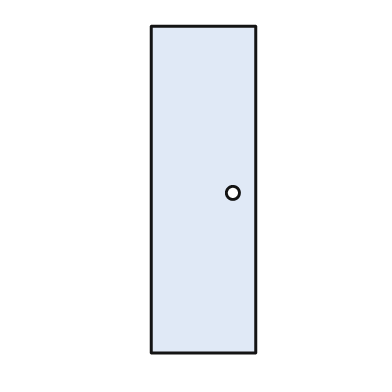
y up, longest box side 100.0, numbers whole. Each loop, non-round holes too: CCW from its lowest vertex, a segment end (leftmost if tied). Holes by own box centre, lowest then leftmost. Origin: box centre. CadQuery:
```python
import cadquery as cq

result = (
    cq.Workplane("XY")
    .moveTo(-16.0, -50.0)
    .lineTo(16.0, -50.0)
    .lineTo(16.0, 50.0)
    .lineTo(-16.0, 50.0)
    .close()
    .moveTo(9.0, -1.0)
    .circle(2.0)
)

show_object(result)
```